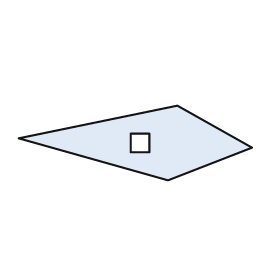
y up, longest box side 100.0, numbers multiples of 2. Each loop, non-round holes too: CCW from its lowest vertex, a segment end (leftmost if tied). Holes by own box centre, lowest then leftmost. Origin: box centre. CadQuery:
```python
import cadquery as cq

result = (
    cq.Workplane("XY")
    .moveTo(14.0, -16.0)
    .lineTo(50.0, -2.0)
    .lineTo(18.0, 16.0)
    .lineTo(-50.0, 2.0)
    .close()
    .moveTo(-2.0, -4.0)
    .lineTo(6.0, -4.0)
    .lineTo(6.0, 4.0)
    .lineTo(-2.0, 4.0)
    .close()
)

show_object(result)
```